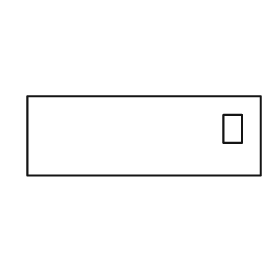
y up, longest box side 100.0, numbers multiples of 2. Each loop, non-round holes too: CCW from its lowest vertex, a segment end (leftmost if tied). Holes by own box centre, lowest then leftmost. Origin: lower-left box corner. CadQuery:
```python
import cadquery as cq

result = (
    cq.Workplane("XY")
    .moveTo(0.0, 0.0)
    .lineTo(100.0, 0.0)
    .lineTo(100.0, 34.0)
    .lineTo(0.0, 34.0)
    .close()
    .moveTo(84.0, 14.0)
    .lineTo(92.0, 14.0)
    .lineTo(92.0, 26.0)
    .lineTo(84.0, 26.0)
    .close()
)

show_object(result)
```